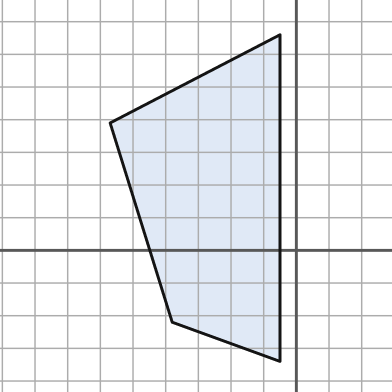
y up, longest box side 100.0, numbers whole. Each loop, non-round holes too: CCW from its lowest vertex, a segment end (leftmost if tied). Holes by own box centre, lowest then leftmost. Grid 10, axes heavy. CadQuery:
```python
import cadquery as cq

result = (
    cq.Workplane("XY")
    .moveTo(-5.0, -34.0)
    .lineTo(-5.0, 66.0)
    .lineTo(-57.0, 39.0)
    .lineTo(-38.0, -22.0)
    .close()
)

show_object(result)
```